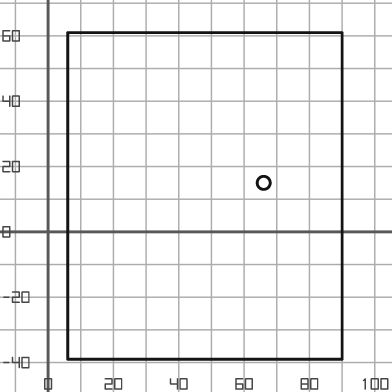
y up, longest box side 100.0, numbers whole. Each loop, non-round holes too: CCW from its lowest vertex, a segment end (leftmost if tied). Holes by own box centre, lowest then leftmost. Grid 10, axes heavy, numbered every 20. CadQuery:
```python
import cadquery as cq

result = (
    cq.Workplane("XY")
    .moveTo(6.0, -39.0)
    .lineTo(90.0, -39.0)
    .lineTo(90.0, 61.0)
    .lineTo(6.0, 61.0)
    .close()
    .moveTo(66.0, 15.0)
    .circle(2.0)
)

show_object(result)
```